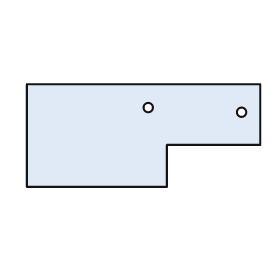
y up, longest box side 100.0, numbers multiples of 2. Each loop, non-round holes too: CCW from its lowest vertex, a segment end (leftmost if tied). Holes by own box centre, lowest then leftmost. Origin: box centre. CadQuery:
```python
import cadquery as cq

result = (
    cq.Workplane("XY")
    .moveTo(-50.0, -22.0)
    .lineTo(10.0, -22.0)
    .lineTo(10.0, -4.0)
    .lineTo(50.0, -4.0)
    .lineTo(50.0, 22.0)
    .lineTo(-50.0, 22.0)
    .close()
    .moveTo(42.0, 10.0)
    .circle(2.0)
    .moveTo(2.0, 12.0)
    .circle(2.0)
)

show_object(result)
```